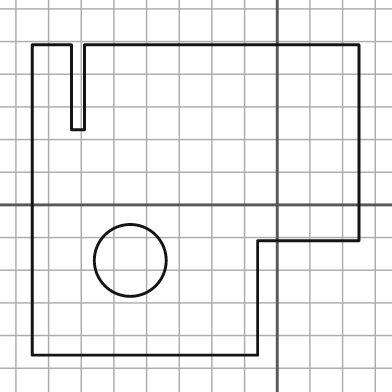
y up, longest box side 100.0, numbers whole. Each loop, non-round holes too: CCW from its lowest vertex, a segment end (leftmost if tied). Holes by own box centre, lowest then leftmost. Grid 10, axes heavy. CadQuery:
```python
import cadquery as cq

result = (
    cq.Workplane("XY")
    .moveTo(-75.0, -46.0)
    .lineTo(-6.0, -46.0)
    .lineTo(-6.0, -11.0)
    .lineTo(25.0, -11.0)
    .lineTo(25.0, 49.0)
    .lineTo(-59.0, 49.0)
    .lineTo(-59.0, 23.0)
    .lineTo(-63.0, 23.0)
    .lineTo(-63.0, 49.0)
    .lineTo(-75.0, 49.0)
    .close()
    .moveTo(-45.0, -17.0)
    .circle(11.0)
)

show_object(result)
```